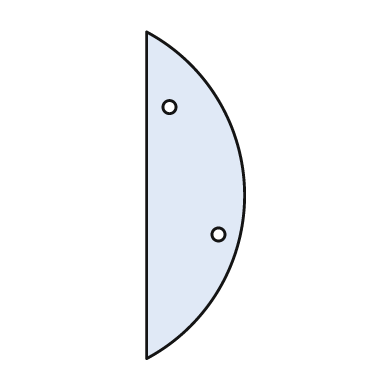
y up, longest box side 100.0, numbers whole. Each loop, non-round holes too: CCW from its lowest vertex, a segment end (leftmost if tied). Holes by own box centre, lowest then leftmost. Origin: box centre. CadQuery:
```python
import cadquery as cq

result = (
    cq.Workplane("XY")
    .moveTo(-15.0, -50.0)
    .threePointArc((15.0, 0.0), (-15.0, 50.0))
    .close()
    .moveTo(7.0, -12.0)
    .circle(2.0)
    .moveTo(-8.0, 27.0)
    .circle(2.0)
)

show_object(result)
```